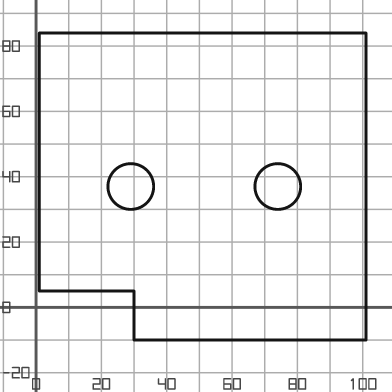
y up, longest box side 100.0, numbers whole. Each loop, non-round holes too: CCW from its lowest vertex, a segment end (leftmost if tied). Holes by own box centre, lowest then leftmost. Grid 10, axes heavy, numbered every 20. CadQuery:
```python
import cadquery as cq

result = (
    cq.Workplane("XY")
    .moveTo(30.0, -10.0)
    .lineTo(101.0, -10.0)
    .lineTo(101.0, 84.0)
    .lineTo(1.0, 84.0)
    .lineTo(1.0, 5.0)
    .lineTo(30.0, 5.0)
    .close()
    .moveTo(29.0, 37.0)
    .circle(7.0)
    .moveTo(74.0, 37.0)
    .circle(7.0)
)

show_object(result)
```